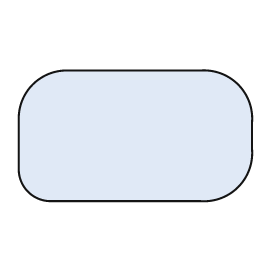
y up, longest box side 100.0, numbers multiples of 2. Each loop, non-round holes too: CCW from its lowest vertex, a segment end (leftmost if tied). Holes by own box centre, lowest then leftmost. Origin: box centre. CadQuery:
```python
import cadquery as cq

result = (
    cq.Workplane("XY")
    .moveTo(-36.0, -28.0)
    .lineTo(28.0, -28.0)
    .threePointArc((44.0, -22.0), (50.0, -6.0))
    .lineTo(50.0, 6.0)
    .threePointArc((44.0, 22.0), (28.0, 28.0))
    .lineTo(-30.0, 28.0)
    .threePointArc((-44.0, 22.0), (-50.0, 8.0))
    .lineTo(-50.0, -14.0)
    .threePointArc((-46.0, -24.0), (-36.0, -28.0))
    .close()
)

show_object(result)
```